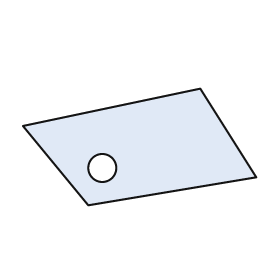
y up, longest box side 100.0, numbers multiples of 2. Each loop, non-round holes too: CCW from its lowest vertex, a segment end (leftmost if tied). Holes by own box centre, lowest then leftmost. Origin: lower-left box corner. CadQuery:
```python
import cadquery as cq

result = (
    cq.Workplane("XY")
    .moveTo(28.0, 0.0)
    .lineTo(100.0, 12.0)
    .lineTo(76.0, 50.0)
    .lineTo(0.0, 34.0)
    .close()
    .moveTo(34.0, 16.0)
    .circle(6.0)
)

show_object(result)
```